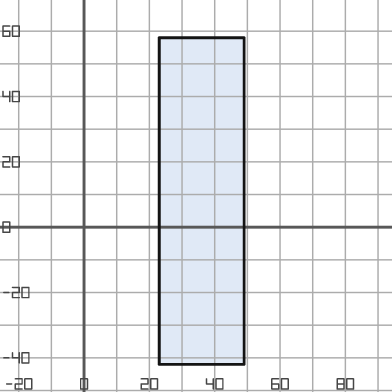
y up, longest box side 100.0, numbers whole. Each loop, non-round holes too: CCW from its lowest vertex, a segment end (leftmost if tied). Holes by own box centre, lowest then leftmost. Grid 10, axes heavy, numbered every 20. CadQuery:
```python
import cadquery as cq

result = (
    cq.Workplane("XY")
    .moveTo(23.0, -42.0)
    .lineTo(49.0, -42.0)
    .lineTo(49.0, 58.0)
    .lineTo(23.0, 58.0)
    .close()
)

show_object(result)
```